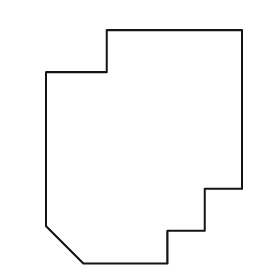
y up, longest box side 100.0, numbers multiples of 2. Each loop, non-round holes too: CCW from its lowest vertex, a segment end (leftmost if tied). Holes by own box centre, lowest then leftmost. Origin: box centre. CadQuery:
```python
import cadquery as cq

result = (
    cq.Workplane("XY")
    .moveTo(-26.0, -50.0)
    .lineTo(10.0, -50.0)
    .lineTo(10.0, -36.0)
    .lineTo(26.0, -36.0)
    .lineTo(26.0, -18.0)
    .lineTo(42.0, -18.0)
    .lineTo(42.0, 50.0)
    .lineTo(-16.0, 50.0)
    .lineTo(-16.0, 32.0)
    .lineTo(-42.0, 32.0)
    .lineTo(-42.0, -34.0)
    .close()
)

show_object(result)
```